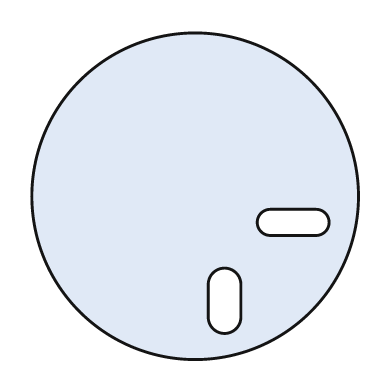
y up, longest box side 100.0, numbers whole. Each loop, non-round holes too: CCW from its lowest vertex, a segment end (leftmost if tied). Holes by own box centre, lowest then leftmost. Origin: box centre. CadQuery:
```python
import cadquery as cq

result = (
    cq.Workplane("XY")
    .moveTo(0.0, 0.0)
    .circle(50.0)
    .moveTo(4.0, -37.0)
    .threePointArc((9.0, -42.0), (14.0, -37.0))
    .lineTo(14.0, -27.0)
    .threePointArc((9.0, -22.0), (4.0, -27.0))
    .close()
    .moveTo(23.0, -12.0)
    .lineTo(37.0, -12.0)
    .threePointArc((41.0, -8.0), (37.0, -4.0))
    .lineTo(23.0, -4.0)
    .threePointArc((19.0, -8.0), (23.0, -12.0))
    .close()
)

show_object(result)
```